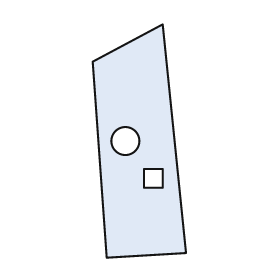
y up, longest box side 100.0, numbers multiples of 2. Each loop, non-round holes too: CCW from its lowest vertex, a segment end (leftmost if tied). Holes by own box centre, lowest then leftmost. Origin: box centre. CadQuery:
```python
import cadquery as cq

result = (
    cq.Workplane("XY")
    .moveTo(-14.0, -50.0)
    .lineTo(20.0, -48.0)
    .lineTo(10.0, 50.0)
    .lineTo(-20.0, 34.0)
    .close()
    .moveTo(2.0, -20.0)
    .lineTo(10.0, -20.0)
    .lineTo(10.0, -12.0)
    .lineTo(2.0, -12.0)
    .close()
    .moveTo(-6.0, 0.0)
    .circle(6.0)
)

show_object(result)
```